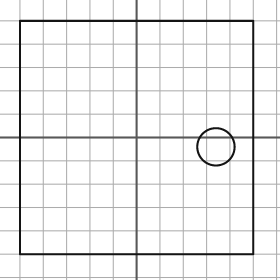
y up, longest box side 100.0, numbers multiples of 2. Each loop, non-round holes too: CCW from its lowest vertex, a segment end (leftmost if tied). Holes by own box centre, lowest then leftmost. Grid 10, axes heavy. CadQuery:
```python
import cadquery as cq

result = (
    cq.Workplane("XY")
    .moveTo(-50.0, -50.0)
    .lineTo(50.0, -50.0)
    .lineTo(50.0, 50.0)
    .lineTo(-50.0, 50.0)
    .close()
    .moveTo(34.0, -4.0)
    .circle(8.0)
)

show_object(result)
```